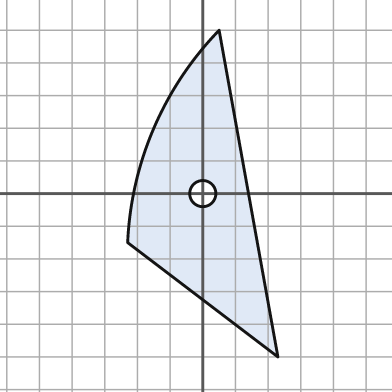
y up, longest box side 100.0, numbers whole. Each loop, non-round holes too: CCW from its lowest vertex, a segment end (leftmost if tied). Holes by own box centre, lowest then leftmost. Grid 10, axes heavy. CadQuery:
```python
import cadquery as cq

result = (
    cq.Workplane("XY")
    .moveTo(23.0, -50.0)
    .lineTo(5.0, 50.0)
    .threePointArc((-15.0, 20.0), (-23.0, -15.0))
    .close()
    .moveTo(0.0, 0.0)
    .circle(4.0)
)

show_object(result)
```